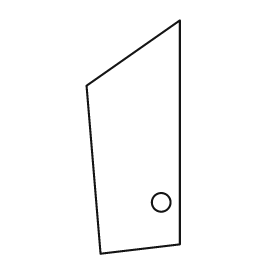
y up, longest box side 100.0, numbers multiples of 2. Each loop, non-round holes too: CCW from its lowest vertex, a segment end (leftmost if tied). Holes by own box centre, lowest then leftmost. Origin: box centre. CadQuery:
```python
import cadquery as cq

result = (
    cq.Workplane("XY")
    .moveTo(-14.0, -50.0)
    .lineTo(20.0, -46.0)
    .lineTo(20.0, 50.0)
    .lineTo(-20.0, 22.0)
    .close()
    .moveTo(12.0, -28.0)
    .circle(4.0)
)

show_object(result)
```